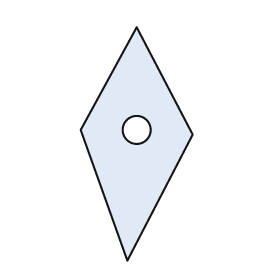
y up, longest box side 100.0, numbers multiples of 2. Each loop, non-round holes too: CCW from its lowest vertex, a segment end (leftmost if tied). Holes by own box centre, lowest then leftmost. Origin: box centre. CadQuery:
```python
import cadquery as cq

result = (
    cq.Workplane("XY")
    .moveTo(-4.0, -50.0)
    .lineTo(24.0, 4.0)
    .lineTo(0.0, 50.0)
    .lineTo(-24.0, 6.0)
    .close()
    .moveTo(0.0, 6.0)
    .circle(6.0)
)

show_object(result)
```